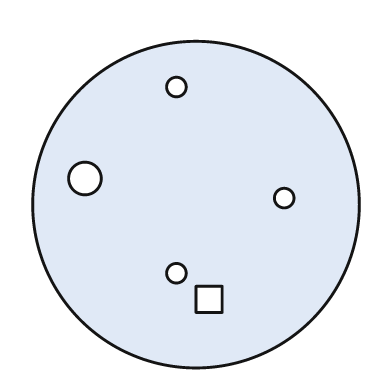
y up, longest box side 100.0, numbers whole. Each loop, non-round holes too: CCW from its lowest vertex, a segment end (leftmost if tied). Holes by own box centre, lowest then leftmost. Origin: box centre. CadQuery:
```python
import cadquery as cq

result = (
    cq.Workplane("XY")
    .moveTo(0.0, 0.0)
    .circle(50.0)
    .moveTo(0.0, -33.0)
    .lineTo(8.0, -33.0)
    .lineTo(8.0, -25.0)
    .lineTo(0.0, -25.0)
    .close()
    .moveTo(-6.0, -21.0)
    .circle(3.0)
    .moveTo(27.0, 2.0)
    .circle(3.0)
    .moveTo(-34.0, 8.0)
    .circle(5.0)
    .moveTo(-6.0, 36.0)
    .circle(3.0)
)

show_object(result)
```